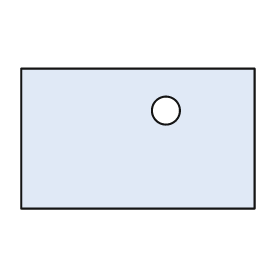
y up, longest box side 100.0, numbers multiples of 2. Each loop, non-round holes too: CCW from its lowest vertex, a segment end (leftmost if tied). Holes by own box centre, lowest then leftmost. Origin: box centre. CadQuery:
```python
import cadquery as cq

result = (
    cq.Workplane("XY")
    .moveTo(-50.0, -30.0)
    .lineTo(50.0, -30.0)
    .lineTo(50.0, 30.0)
    .lineTo(-50.0, 30.0)
    .close()
    .moveTo(12.0, 12.0)
    .circle(6.0)
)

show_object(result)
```